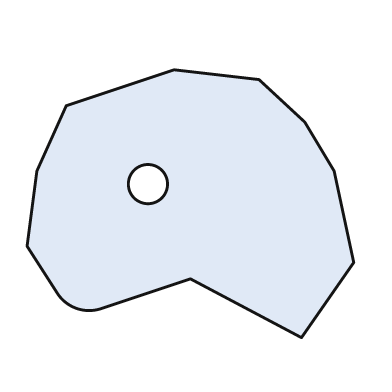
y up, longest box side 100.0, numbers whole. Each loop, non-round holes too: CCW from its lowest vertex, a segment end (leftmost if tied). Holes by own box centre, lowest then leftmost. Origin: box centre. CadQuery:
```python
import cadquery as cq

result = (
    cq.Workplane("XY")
    .moveTo(34.0, -41.0)
    .lineTo(50.0, -18.0)
    .lineTo(44.0, 10.0)
    .lineTo(35.0, 25.0)
    .lineTo(21.0, 38.0)
    .lineTo(-5.0, 41.0)
    .lineTo(-38.0, 30.0)
    .lineTo(-47.0, 10.0)
    .lineTo(-50.0, -13.0)
    .lineTo(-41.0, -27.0)
    .threePointArc((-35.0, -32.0), (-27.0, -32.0))
    .lineTo(0.0, -23.0)
    .close()
    .moveTo(-13.0, 6.0)
    .circle(6.0)
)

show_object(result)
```